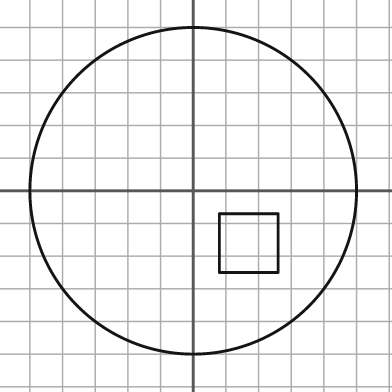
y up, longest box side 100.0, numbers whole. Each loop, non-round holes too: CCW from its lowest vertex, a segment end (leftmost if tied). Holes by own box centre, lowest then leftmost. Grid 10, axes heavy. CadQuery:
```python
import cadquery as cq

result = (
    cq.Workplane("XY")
    .moveTo(0.0, 0.0)
    .circle(50.0)
    .moveTo(8.0, -25.0)
    .lineTo(26.0, -25.0)
    .lineTo(26.0, -7.0)
    .lineTo(8.0, -7.0)
    .close()
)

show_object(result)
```